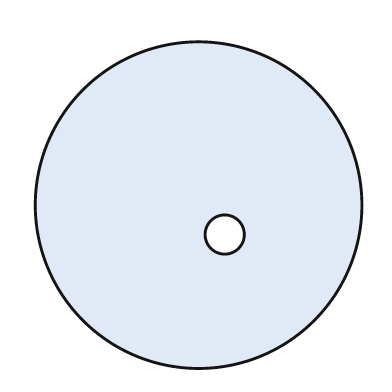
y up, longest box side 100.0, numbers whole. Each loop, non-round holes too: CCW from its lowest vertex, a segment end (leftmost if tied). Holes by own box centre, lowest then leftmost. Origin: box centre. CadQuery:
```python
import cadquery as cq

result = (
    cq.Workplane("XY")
    .moveTo(0.0, 0.0)
    .circle(50.0)
    .moveTo(8.0, -9.0)
    .circle(6.0)
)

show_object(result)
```